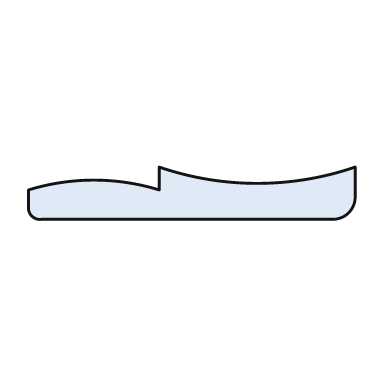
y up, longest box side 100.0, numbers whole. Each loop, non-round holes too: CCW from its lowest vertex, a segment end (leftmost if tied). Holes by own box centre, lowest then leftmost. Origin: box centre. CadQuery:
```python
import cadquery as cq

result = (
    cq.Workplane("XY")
    .moveTo(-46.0, -8.0)
    .lineTo(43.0, -8.0)
    .threePointArc((48.0, -6.0), (50.0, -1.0))
    .lineTo(50.0, 8.0)
    .threePointArc((20.0, 3.0), (-10.0, 8.0))
    .lineTo(-10.0, 1.0)
    .threePointArc((-30.0, 4.0), (-50.0, 1.0))
    .lineTo(-50.0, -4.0)
    .threePointArc((-49.0, -7.0), (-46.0, -8.0))
    .close()
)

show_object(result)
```